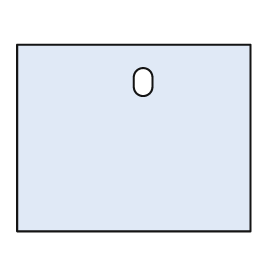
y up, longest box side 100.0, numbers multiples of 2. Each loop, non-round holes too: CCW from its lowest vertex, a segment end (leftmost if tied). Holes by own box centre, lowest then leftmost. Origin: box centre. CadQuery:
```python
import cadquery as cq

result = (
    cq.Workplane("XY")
    .moveTo(-50.0, -40.0)
    .lineTo(50.0, -40.0)
    .lineTo(50.0, 40.0)
    .lineTo(-50.0, 40.0)
    .close()
    .moveTo(0.0, 22.0)
    .threePointArc((4.0, 18.0), (8.0, 22.0))
    .lineTo(8.0, 26.0)
    .threePointArc((4.0, 30.0), (0.0, 26.0))
    .close()
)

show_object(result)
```